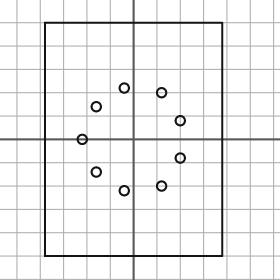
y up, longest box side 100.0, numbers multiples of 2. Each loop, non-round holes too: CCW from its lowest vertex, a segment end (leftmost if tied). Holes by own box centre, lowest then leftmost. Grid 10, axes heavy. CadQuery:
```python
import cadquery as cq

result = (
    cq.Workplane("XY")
    .moveTo(-38.0, -50.0)
    .lineTo(38.0, -50.0)
    .lineTo(38.0, 50.0)
    .lineTo(-38.0, 50.0)
    .close()
    .moveTo(-4.0, -22.0)
    .circle(2.0)
    .moveTo(12.0, -20.0)
    .circle(2.0)
    .moveTo(-16.0, -14.0)
    .circle(2.0)
    .moveTo(20.0, -8.0)
    .circle(2.0)
    .moveTo(-22.0, 0.0)
    .circle(2.0)
    .moveTo(20.0, 8.0)
    .circle(2.0)
    .moveTo(-16.0, 14.0)
    .circle(2.0)
    .moveTo(12.0, 20.0)
    .circle(2.0)
    .moveTo(-4.0, 22.0)
    .circle(2.0)
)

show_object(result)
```